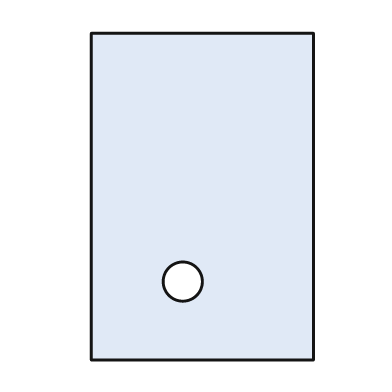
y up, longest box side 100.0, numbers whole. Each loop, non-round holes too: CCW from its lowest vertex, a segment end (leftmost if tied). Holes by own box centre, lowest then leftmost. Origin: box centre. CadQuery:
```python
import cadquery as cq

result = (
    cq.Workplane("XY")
    .moveTo(-34.0, -50.0)
    .lineTo(34.0, -50.0)
    .lineTo(34.0, 50.0)
    .lineTo(-34.0, 50.0)
    .close()
    .moveTo(-6.0, -26.0)
    .circle(6.0)
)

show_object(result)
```